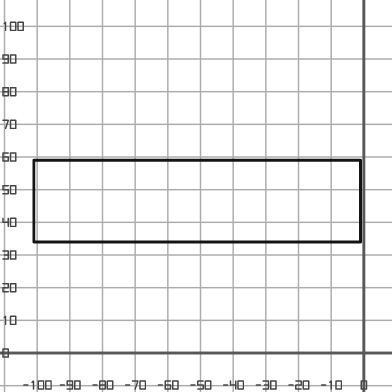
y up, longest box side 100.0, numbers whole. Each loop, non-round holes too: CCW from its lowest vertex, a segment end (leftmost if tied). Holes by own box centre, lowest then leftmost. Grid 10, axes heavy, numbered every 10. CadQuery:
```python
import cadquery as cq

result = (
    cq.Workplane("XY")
    .moveTo(-101.0, 34.0)
    .lineTo(-1.0, 34.0)
    .lineTo(-1.0, 59.0)
    .lineTo(-101.0, 59.0)
    .close()
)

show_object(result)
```